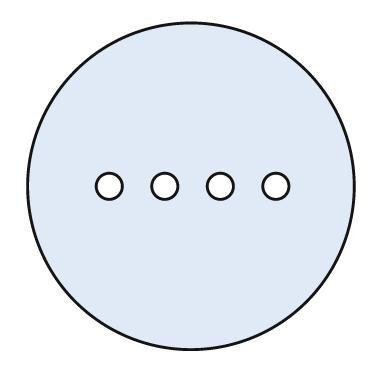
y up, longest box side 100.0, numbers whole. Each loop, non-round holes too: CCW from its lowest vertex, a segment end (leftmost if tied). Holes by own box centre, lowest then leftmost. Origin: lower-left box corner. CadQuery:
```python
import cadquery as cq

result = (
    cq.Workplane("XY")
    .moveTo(50.0, 50.0)
    .circle(50.0)
    .moveTo(25.0, 50.0)
    .circle(4.0)
    .moveTo(42.0, 50.0)
    .circle(4.0)
    .moveTo(59.0, 50.0)
    .circle(4.0)
    .moveTo(76.0, 50.0)
    .circle(4.0)
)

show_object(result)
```